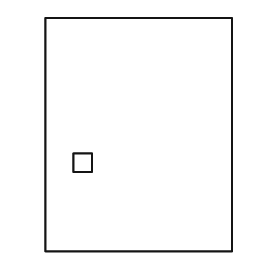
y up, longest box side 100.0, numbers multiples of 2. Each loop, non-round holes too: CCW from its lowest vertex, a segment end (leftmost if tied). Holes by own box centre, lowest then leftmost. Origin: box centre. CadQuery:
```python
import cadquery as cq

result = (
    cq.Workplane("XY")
    .moveTo(-40.0, -50.0)
    .lineTo(40.0, -50.0)
    .lineTo(40.0, 50.0)
    .lineTo(-40.0, 50.0)
    .close()
    .moveTo(-28.0, -16.0)
    .lineTo(-20.0, -16.0)
    .lineTo(-20.0, -8.0)
    .lineTo(-28.0, -8.0)
    .close()
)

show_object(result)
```